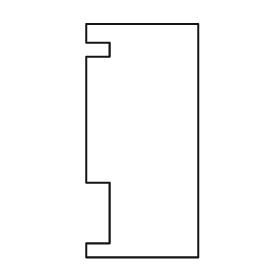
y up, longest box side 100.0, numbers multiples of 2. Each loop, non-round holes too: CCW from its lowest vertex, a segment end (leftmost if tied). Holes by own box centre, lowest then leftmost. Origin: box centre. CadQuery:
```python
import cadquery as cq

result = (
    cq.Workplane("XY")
    .moveTo(-24.0, -50.0)
    .lineTo(24.0, -50.0)
    .lineTo(24.0, 50.0)
    .lineTo(-24.0, 50.0)
    .lineTo(-24.0, 42.0)
    .lineTo(-14.0, 42.0)
    .lineTo(-14.0, 36.0)
    .lineTo(-24.0, 36.0)
    .lineTo(-24.0, -18.0)
    .lineTo(-14.0, -18.0)
    .lineTo(-14.0, -44.0)
    .lineTo(-24.0, -44.0)
    .close()
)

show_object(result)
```